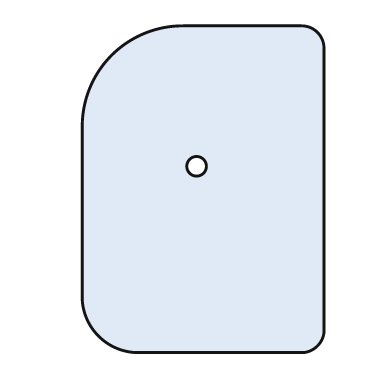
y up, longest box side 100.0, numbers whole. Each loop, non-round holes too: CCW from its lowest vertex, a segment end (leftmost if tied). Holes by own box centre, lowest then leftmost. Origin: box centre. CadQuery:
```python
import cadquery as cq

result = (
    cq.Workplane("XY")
    .moveTo(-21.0, -50.0)
    .lineTo(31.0, -50.0)
    .threePointArc((35.0, -48.0), (37.0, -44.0))
    .lineTo(37.0, 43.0)
    .threePointArc((35.0, 48.0), (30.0, 50.0))
    .lineTo(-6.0, 50.0)
    .threePointArc((-28.0, 41.0), (-37.0, 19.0))
    .lineTo(-37.0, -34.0)
    .threePointArc((-32.0, -45.0), (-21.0, -50.0))
    .close()
    .moveTo(-2.0, 7.0)
    .circle(3.0)
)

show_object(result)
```